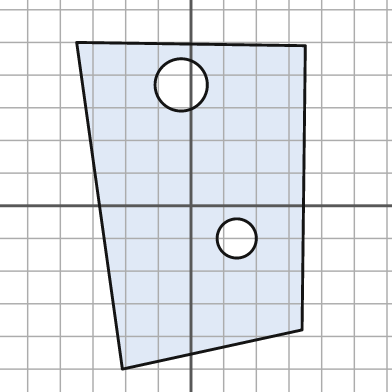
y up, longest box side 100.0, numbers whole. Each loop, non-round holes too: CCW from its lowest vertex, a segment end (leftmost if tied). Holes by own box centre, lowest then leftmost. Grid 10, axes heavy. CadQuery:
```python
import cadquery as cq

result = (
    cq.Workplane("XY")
    .moveTo(-21.0, -50.0)
    .lineTo(34.0, -38.0)
    .lineTo(35.0, 49.0)
    .lineTo(-35.0, 50.0)
    .close()
    .moveTo(14.0, -10.0)
    .circle(6.0)
    .moveTo(-3.0, 37.0)
    .circle(8.0)
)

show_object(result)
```